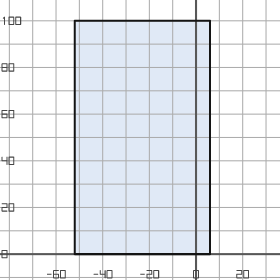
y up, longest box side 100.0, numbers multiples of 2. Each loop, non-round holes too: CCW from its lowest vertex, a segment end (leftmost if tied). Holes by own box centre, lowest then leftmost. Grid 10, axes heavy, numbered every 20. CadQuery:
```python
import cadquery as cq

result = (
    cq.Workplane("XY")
    .moveTo(-52.0, 0.0)
    .lineTo(6.0, 0.0)
    .lineTo(6.0, 100.0)
    .lineTo(-52.0, 100.0)
    .close()
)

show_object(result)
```